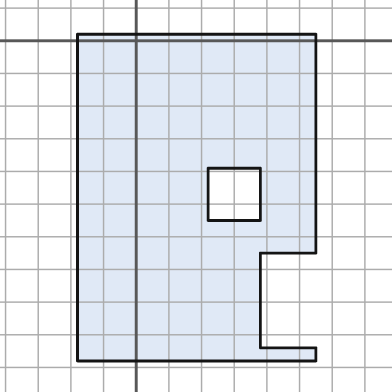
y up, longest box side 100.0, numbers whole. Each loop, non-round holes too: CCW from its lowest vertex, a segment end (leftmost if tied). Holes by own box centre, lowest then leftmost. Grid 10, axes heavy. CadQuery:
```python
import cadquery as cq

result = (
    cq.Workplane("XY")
    .moveTo(-18.0, -98.0)
    .lineTo(55.0, -98.0)
    .lineTo(55.0, -94.0)
    .lineTo(38.0, -94.0)
    .lineTo(38.0, -65.0)
    .lineTo(55.0, -65.0)
    .lineTo(55.0, 2.0)
    .lineTo(-18.0, 2.0)
    .close()
    .moveTo(22.0, -55.0)
    .lineTo(38.0, -55.0)
    .lineTo(38.0, -39.0)
    .lineTo(22.0, -39.0)
    .close()
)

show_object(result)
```